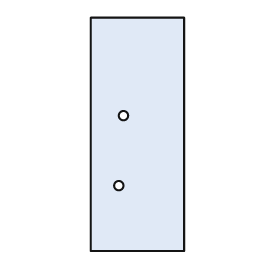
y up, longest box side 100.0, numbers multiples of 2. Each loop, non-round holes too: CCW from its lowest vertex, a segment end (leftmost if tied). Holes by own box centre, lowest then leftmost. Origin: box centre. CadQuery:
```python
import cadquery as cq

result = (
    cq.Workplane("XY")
    .moveTo(-20.0, -50.0)
    .lineTo(20.0, -50.0)
    .lineTo(20.0, 50.0)
    .lineTo(-20.0, 50.0)
    .close()
    .moveTo(-8.0, -22.0)
    .circle(2.0)
    .moveTo(-6.0, 8.0)
    .circle(2.0)
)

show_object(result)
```